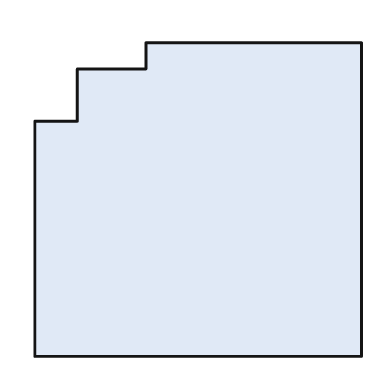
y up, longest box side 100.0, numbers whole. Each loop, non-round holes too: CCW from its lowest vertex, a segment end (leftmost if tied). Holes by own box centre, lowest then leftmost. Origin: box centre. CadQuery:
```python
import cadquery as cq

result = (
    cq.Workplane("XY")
    .moveTo(-50.0, -48.0)
    .lineTo(50.0, -48.0)
    .lineTo(50.0, 48.0)
    .lineTo(-16.0, 48.0)
    .lineTo(-16.0, 40.0)
    .lineTo(-37.0, 40.0)
    .lineTo(-37.0, 24.0)
    .lineTo(-50.0, 24.0)
    .close()
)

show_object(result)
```